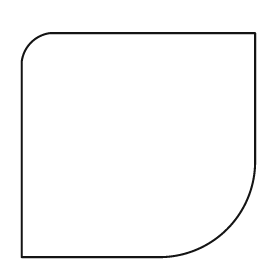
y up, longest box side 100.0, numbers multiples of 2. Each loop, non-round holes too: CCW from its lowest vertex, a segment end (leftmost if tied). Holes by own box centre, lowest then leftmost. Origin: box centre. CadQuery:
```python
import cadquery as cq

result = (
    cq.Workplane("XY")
    .moveTo(-50.0, -48.0)
    .lineTo(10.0, -48.0)
    .threePointArc((38.0, -36.0), (50.0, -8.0))
    .lineTo(50.0, 48.0)
    .lineTo(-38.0, 48.0)
    .threePointArc((-46.0, 44.0), (-50.0, 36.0))
    .close()
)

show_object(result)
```